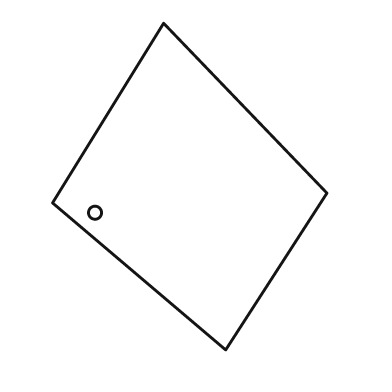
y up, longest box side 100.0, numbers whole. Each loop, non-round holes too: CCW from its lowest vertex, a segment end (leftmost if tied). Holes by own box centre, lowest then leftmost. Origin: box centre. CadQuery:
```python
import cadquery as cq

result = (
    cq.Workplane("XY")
    .moveTo(11.0, -50.0)
    .lineTo(42.0, -2.0)
    .lineTo(-8.0, 50.0)
    .lineTo(-42.0, -5.0)
    .close()
    .moveTo(-29.0, -8.0)
    .circle(2.0)
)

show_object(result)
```